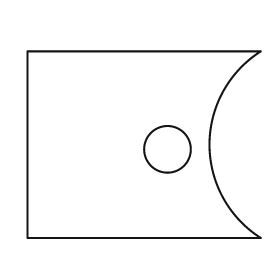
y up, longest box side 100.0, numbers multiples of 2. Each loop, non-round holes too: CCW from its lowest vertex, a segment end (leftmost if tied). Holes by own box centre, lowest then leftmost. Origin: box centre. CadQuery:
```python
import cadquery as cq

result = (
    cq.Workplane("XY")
    .moveTo(-50.0, -40.0)
    .lineTo(50.0, -40.0)
    .threePointArc((28.0, 0.0), (50.0, 40.0))
    .lineTo(-50.0, 40.0)
    .close()
    .moveTo(10.0, -2.0)
    .circle(10.0)
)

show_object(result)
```